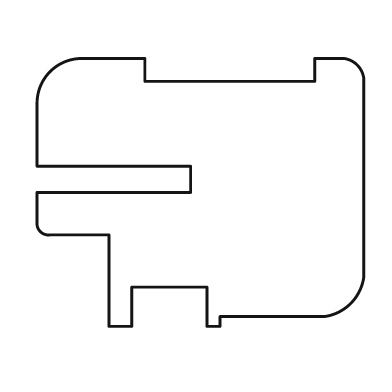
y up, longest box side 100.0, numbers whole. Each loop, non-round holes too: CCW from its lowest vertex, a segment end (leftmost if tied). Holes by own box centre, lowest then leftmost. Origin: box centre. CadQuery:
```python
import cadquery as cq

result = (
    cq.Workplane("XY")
    .moveTo(-28.0, -41.0)
    .lineTo(-21.0, -41.0)
    .lineTo(-21.0, -29.0)
    .lineTo(2.0, -29.0)
    .lineTo(2.0, -41.0)
    .lineTo(6.0, -41.0)
    .lineTo(6.0, -38.0)
    .lineTo(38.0, -38.0)
    .threePointArc((46.0, -34.0), (50.0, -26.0))
    .lineTo(50.0, 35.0)
    .threePointArc((48.0, 39.0), (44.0, 41.0))
    .lineTo(35.0, 41.0)
    .lineTo(35.0, 34.0)
    .lineTo(-17.0, 34.0)
    .lineTo(-17.0, 41.0)
    .lineTo(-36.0, 41.0)
    .threePointArc((-46.0, 37.0), (-50.0, 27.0))
    .lineTo(-50.0, 8.0)
    .lineTo(-3.0, 8.0)
    .lineTo(-3.0, 0.0)
    .lineTo(-50.0, 0.0)
    .lineTo(-50.0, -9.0)
    .threePointArc((-49.0, -12.0), (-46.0, -13.0))
    .lineTo(-28.0, -13.0)
    .close()
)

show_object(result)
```